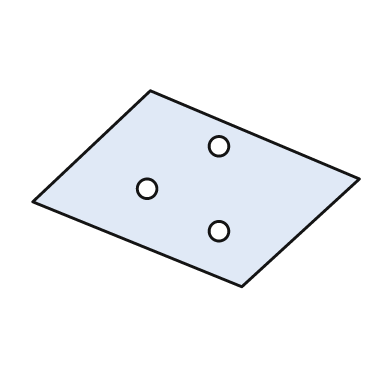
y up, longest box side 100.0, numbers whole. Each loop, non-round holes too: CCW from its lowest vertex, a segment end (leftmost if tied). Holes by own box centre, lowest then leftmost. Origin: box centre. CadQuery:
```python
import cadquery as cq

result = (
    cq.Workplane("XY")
    .moveTo(14.0, -30.0)
    .lineTo(50.0, 3.0)
    .lineTo(-14.0, 30.0)
    .lineTo(-50.0, -4.0)
    .close()
    .moveTo(7.0, -13.0)
    .circle(3.0)
    .moveTo(-15.0, 0.0)
    .circle(3.0)
    .moveTo(7.0, 13.0)
    .circle(3.0)
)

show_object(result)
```